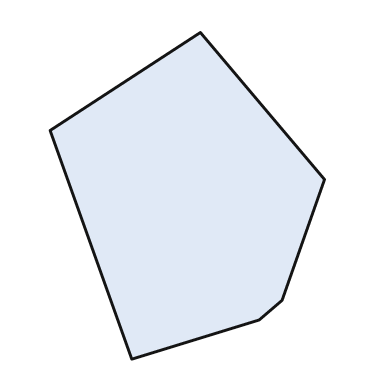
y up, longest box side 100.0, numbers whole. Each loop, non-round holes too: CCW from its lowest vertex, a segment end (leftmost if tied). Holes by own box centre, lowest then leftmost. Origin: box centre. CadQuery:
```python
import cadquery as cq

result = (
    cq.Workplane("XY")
    .moveTo(-17.0, -50.0)
    .lineTo(22.0, -38.0)
    .lineTo(29.0, -32.0)
    .lineTo(42.0, 5.0)
    .lineTo(4.0, 50.0)
    .lineTo(-42.0, 20.0)
    .close()
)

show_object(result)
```